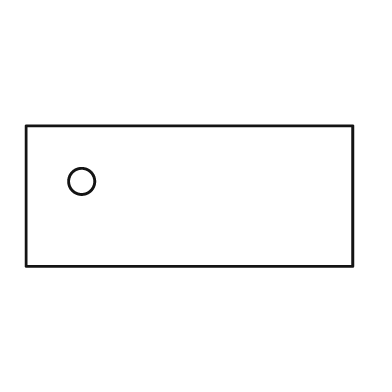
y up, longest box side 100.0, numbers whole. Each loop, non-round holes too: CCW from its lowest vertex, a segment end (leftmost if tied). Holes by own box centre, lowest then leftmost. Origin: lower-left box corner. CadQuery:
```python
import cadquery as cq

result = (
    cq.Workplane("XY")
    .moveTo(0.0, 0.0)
    .lineTo(100.0, 0.0)
    .lineTo(100.0, 43.0)
    .lineTo(0.0, 43.0)
    .close()
    .moveTo(17.0, 26.0)
    .circle(4.0)
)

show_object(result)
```